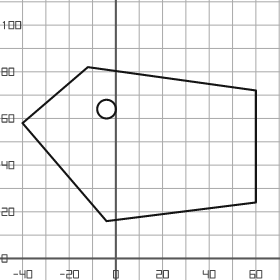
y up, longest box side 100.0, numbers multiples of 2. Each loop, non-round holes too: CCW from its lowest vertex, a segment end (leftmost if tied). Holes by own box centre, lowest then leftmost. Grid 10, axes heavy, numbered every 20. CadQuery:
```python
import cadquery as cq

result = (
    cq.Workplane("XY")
    .moveTo(-4.0, 16.0)
    .lineTo(60.0, 24.0)
    .lineTo(60.0, 72.0)
    .lineTo(-12.0, 82.0)
    .lineTo(-40.0, 58.0)
    .close()
    .moveTo(-4.0, 64.0)
    .circle(4.0)
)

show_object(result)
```